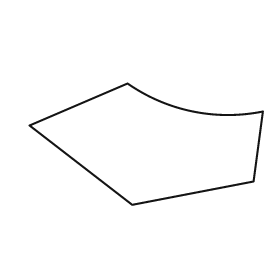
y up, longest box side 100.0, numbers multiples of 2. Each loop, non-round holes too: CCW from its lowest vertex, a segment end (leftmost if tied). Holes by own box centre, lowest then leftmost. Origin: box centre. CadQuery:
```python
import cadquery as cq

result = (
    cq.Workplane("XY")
    .moveTo(-6.0, -26.0)
    .lineTo(46.0, -16.0)
    .lineTo(50.0, 14.0)
    .threePointArc((20.0, 14.0), (-8.0, 26.0))
    .lineTo(-50.0, 8.0)
    .close()
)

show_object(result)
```